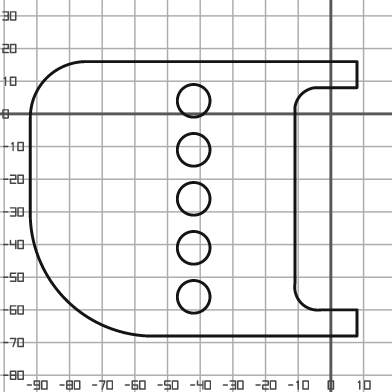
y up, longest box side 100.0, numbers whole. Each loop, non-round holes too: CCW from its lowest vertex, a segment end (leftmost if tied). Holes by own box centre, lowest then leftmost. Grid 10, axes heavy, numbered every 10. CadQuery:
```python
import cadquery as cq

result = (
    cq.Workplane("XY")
    .moveTo(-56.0, -68.0)
    .lineTo(8.0, -68.0)
    .lineTo(8.0, -60.0)
    .lineTo(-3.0, -60.0)
    .threePointArc((-9.0, -58.0), (-11.0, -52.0))
    .lineTo(-11.0, 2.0)
    .threePointArc((-9.0, 6.0), (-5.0, 8.0))
    .lineTo(8.0, 8.0)
    .lineTo(8.0, 16.0)
    .lineTo(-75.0, 16.0)
    .threePointArc((-87.0, 11.0), (-92.0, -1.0))
    .lineTo(-92.0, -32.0)
    .threePointArc((-81.0, -57.0), (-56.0, -68.0))
    .close()
    .moveTo(-42.0, -56.0)
    .circle(5.0)
    .moveTo(-42.0, -41.0)
    .circle(5.0)
    .moveTo(-42.0, -26.0)
    .circle(5.0)
    .moveTo(-42.0, -11.0)
    .circle(5.0)
    .moveTo(-42.0, 4.0)
    .circle(5.0)
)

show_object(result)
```